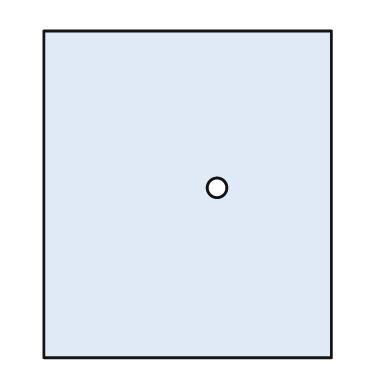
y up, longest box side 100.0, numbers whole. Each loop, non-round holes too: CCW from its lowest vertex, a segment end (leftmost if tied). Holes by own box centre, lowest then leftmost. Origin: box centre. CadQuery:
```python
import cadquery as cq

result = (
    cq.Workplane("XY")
    .moveTo(-44.0, -50.0)
    .lineTo(44.0, -50.0)
    .lineTo(44.0, 50.0)
    .lineTo(-44.0, 50.0)
    .close()
    .moveTo(9.0, 2.0)
    .circle(3.0)
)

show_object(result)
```